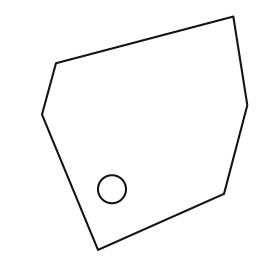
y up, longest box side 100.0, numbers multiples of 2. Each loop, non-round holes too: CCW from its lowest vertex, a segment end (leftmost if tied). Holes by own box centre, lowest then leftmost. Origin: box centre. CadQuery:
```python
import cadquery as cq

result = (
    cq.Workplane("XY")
    .moveTo(-20.0, -50.0)
    .lineTo(34.0, -26.0)
    .lineTo(44.0, 12.0)
    .lineTo(38.0, 50.0)
    .lineTo(-38.0, 30.0)
    .lineTo(-44.0, 8.0)
    .close()
    .moveTo(-14.0, -24.0)
    .circle(6.0)
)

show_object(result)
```